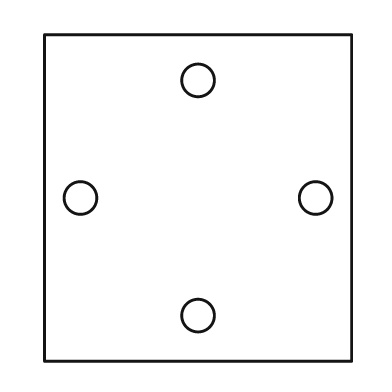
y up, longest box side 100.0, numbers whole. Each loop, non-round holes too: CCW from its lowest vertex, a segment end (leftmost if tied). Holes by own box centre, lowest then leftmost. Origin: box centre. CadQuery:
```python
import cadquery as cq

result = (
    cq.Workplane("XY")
    .moveTo(-47.0, -50.0)
    .lineTo(47.0, -50.0)
    .lineTo(47.0, 50.0)
    .lineTo(-47.0, 50.0)
    .close()
    .moveTo(0.0, -36.0)
    .circle(5.0)
    .moveTo(-36.0, 0.0)
    .circle(5.0)
    .moveTo(36.0, 0.0)
    .circle(5.0)
    .moveTo(0.0, 36.0)
    .circle(5.0)
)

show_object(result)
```